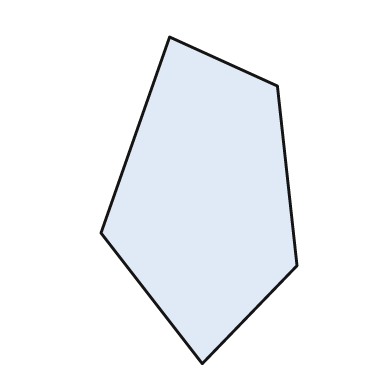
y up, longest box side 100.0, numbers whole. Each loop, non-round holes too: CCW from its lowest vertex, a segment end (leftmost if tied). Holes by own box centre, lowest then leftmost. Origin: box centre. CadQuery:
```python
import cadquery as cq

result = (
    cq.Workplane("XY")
    .moveTo(1.0, -50.0)
    .lineTo(30.0, -20.0)
    .lineTo(24.0, 35.0)
    .lineTo(-9.0, 50.0)
    .lineTo(-30.0, -10.0)
    .close()
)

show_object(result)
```